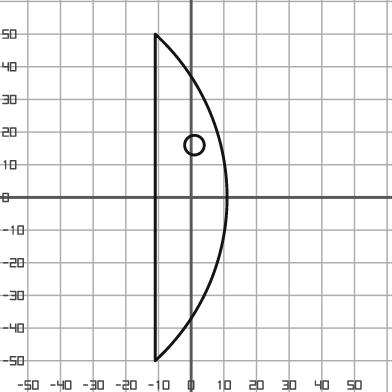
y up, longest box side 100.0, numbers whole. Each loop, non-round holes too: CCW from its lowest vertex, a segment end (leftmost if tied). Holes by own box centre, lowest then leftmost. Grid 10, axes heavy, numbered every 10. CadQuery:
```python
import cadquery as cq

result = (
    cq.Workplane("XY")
    .moveTo(-11.0, -50.0)
    .threePointArc((11.0, 0.0), (-11.0, 50.0))
    .close()
    .moveTo(1.0, 16.0)
    .circle(3.0)
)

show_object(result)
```